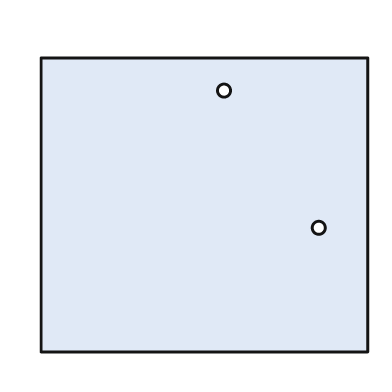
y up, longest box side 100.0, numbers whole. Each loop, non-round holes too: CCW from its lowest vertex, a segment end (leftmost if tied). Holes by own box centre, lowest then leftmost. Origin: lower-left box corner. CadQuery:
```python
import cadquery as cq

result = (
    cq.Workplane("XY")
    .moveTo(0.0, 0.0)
    .lineTo(100.0, 0.0)
    .lineTo(100.0, 90.0)
    .lineTo(0.0, 90.0)
    .close()
    .moveTo(85.0, 38.0)
    .circle(2.0)
    .moveTo(56.0, 80.0)
    .circle(2.0)
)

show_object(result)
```